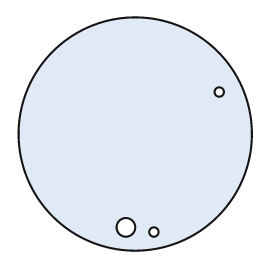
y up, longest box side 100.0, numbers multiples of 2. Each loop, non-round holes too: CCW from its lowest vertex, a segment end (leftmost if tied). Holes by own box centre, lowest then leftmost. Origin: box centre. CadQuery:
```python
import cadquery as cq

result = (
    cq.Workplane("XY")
    .moveTo(0.0, 0.0)
    .circle(50.0)
    .moveTo(8.0, -42.0)
    .circle(2.0)
    .moveTo(-4.0, -40.0)
    .circle(4.0)
    .moveTo(36.0, 18.0)
    .circle(2.0)
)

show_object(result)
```